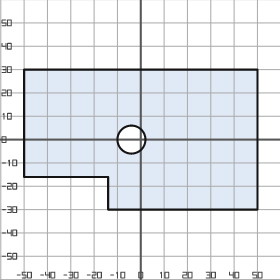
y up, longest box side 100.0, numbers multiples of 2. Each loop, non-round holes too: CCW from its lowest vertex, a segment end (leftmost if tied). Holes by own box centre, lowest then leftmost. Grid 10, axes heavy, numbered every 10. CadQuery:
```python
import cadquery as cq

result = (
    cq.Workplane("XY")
    .moveTo(-14.0, -30.0)
    .lineTo(50.0, -30.0)
    .lineTo(50.0, 30.0)
    .lineTo(-50.0, 30.0)
    .lineTo(-50.0, -16.0)
    .lineTo(-14.0, -16.0)
    .close()
    .moveTo(-4.0, 0.0)
    .circle(6.0)
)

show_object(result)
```